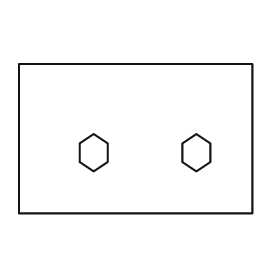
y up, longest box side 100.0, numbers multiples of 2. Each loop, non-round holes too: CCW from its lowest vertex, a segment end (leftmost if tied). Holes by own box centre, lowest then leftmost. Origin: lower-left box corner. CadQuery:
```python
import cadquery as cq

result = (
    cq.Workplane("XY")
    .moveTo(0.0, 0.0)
    .lineTo(100.0, 0.0)
    .lineTo(100.0, 64.0)
    .lineTo(0.0, 64.0)
    .close()
    .moveTo(32.0, 18.0)
    .lineTo(38.0, 22.0)
    .lineTo(38.0, 30.0)
    .lineTo(32.0, 34.0)
    .lineTo(26.0, 30.0)
    .lineTo(26.0, 22.0)
    .close()
    .moveTo(76.0, 18.0)
    .lineTo(82.0, 22.0)
    .lineTo(82.0, 30.0)
    .lineTo(76.0, 34.0)
    .lineTo(70.0, 30.0)
    .lineTo(70.0, 22.0)
    .close()
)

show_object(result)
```